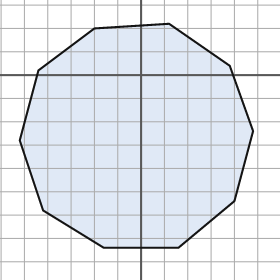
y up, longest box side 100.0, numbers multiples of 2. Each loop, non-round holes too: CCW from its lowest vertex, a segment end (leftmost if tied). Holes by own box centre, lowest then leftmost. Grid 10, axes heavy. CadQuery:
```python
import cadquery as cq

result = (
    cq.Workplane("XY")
    .moveTo(-16.0, -74.0)
    .lineTo(16.0, -74.0)
    .lineTo(40.0, -54.0)
    .lineTo(48.0, -24.0)
    .lineTo(38.0, 4.0)
    .lineTo(12.0, 22.0)
    .lineTo(-20.0, 20.0)
    .lineTo(-44.0, 2.0)
    .lineTo(-52.0, -28.0)
    .lineTo(-42.0, -58.0)
    .close()
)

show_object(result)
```